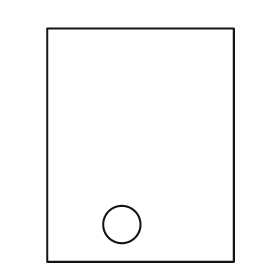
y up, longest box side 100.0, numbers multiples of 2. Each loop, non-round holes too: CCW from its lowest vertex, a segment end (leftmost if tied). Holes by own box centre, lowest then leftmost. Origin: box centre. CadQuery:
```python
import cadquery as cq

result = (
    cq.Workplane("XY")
    .moveTo(-40.0, -50.0)
    .lineTo(40.0, -50.0)
    .lineTo(40.0, 50.0)
    .lineTo(-40.0, 50.0)
    .close()
    .moveTo(-8.0, -34.0)
    .circle(8.0)
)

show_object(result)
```